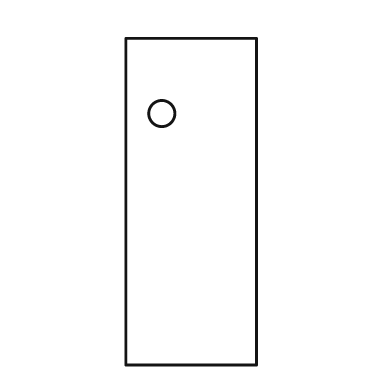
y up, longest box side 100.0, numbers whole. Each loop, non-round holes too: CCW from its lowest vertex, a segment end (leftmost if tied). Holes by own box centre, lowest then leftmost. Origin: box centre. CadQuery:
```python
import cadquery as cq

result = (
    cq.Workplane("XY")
    .moveTo(-20.0, -50.0)
    .lineTo(20.0, -50.0)
    .lineTo(20.0, 50.0)
    .lineTo(-20.0, 50.0)
    .close()
    .moveTo(-9.0, 27.0)
    .circle(4.0)
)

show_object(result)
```